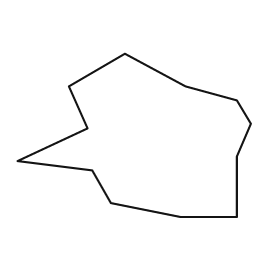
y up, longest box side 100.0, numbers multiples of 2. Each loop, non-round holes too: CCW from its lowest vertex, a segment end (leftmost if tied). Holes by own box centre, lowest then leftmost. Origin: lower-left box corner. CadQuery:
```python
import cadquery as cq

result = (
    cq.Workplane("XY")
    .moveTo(70.0, 0.0)
    .lineTo(94.0, 0.0)
    .lineTo(94.0, 26.0)
    .lineTo(100.0, 40.0)
    .lineTo(94.0, 50.0)
    .lineTo(72.0, 56.0)
    .lineTo(46.0, 70.0)
    .lineTo(22.0, 56.0)
    .lineTo(30.0, 38.0)
    .lineTo(0.0, 24.0)
    .lineTo(32.0, 20.0)
    .lineTo(40.0, 6.0)
    .close()
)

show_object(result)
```